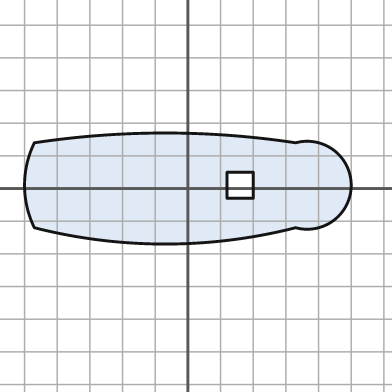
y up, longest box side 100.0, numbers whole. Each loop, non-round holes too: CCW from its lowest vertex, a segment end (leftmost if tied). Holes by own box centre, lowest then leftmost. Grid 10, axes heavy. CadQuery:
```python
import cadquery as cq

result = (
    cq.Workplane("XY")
    .moveTo(-47.0, -12.0)
    .threePointArc((-7.0, -17.0), (33.0, -12.0))
    .threePointArc((50.0, 1.0), (33.0, 14.0))
    .threePointArc((-7.0, 17.0), (-47.0, 14.0))
    .threePointArc((-50.0, 1.0), (-47.0, -12.0))
    .close()
    .moveTo(12.0, -3.0)
    .lineTo(20.0, -3.0)
    .lineTo(20.0, 5.0)
    .lineTo(12.0, 5.0)
    .close()
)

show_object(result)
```